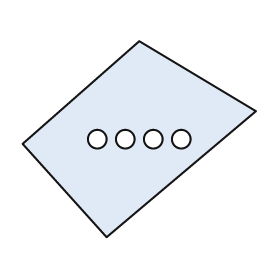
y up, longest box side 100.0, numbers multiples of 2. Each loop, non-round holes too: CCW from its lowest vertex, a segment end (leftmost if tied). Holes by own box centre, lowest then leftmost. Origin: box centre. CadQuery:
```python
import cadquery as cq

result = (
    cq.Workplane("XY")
    .moveTo(-14.0, -42.0)
    .lineTo(50.0, 12.0)
    .lineTo(0.0, 42.0)
    .lineTo(-50.0, -2.0)
    .close()
    .moveTo(-18.0, 0.0)
    .circle(4.0)
    .moveTo(-6.0, 0.0)
    .circle(4.0)
    .moveTo(6.0, 0.0)
    .circle(4.0)
    .moveTo(18.0, 0.0)
    .circle(4.0)
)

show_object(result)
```